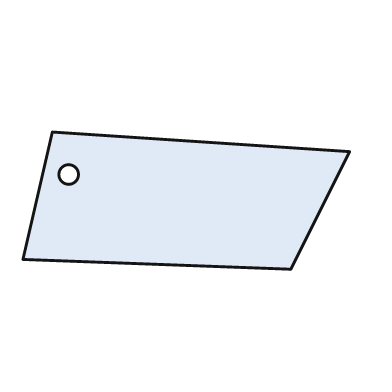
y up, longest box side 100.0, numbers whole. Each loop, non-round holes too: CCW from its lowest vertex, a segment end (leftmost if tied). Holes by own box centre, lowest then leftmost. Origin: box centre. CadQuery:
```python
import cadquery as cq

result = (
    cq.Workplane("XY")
    .moveTo(32.0, -21.0)
    .lineTo(50.0, 15.0)
    .lineTo(-41.0, 21.0)
    .lineTo(-50.0, -18.0)
    .close()
    .moveTo(-36.0, 8.0)
    .circle(3.0)
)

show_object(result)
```